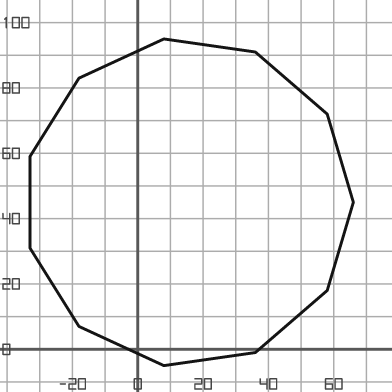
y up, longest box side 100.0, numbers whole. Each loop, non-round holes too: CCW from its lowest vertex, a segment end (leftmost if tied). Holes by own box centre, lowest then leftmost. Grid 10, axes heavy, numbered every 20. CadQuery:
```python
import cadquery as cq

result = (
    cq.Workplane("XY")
    .moveTo(8.0, -5.0)
    .lineTo(36.0, -1.0)
    .lineTo(58.0, 18.0)
    .lineTo(66.0, 45.0)
    .lineTo(58.0, 72.0)
    .lineTo(36.0, 91.0)
    .lineTo(8.0, 95.0)
    .lineTo(-18.0, 83.0)
    .lineTo(-33.0, 59.0)
    .lineTo(-33.0, 31.0)
    .lineTo(-18.0, 7.0)
    .close()
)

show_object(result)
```